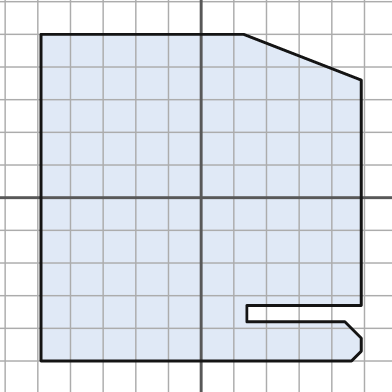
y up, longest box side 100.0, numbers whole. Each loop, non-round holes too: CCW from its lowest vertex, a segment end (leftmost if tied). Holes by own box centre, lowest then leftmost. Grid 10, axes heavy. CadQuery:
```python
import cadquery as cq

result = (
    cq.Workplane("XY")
    .moveTo(-49.0, -50.0)
    .lineTo(46.0, -50.0)
    .lineTo(49.0, -47.0)
    .lineTo(49.0, -43.0)
    .lineTo(44.0, -38.0)
    .lineTo(14.0, -38.0)
    .lineTo(14.0, -33.0)
    .lineTo(49.0, -33.0)
    .lineTo(49.0, 36.0)
    .lineTo(13.0, 50.0)
    .lineTo(-49.0, 50.0)
    .close()
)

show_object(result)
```